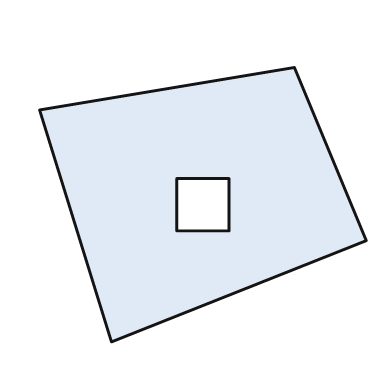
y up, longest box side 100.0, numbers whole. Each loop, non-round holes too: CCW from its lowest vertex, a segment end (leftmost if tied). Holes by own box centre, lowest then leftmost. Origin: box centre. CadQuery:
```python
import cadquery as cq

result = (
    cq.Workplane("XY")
    .moveTo(-28.0, -42.0)
    .lineTo(50.0, -11.0)
    .lineTo(28.0, 42.0)
    .lineTo(-50.0, 29.0)
    .close()
    .moveTo(-8.0, -8.0)
    .lineTo(8.0, -8.0)
    .lineTo(8.0, 8.0)
    .lineTo(-8.0, 8.0)
    .close()
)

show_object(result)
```